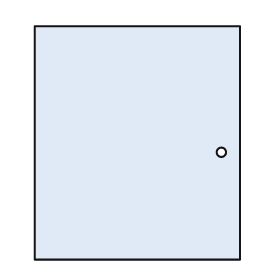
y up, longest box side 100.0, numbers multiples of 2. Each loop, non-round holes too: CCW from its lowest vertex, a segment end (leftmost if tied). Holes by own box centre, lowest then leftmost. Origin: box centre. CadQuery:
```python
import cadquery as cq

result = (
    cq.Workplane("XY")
    .moveTo(-44.0, -50.0)
    .lineTo(44.0, -50.0)
    .lineTo(44.0, 50.0)
    .lineTo(-44.0, 50.0)
    .close()
    .moveTo(36.0, -4.0)
    .circle(2.0)
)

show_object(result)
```